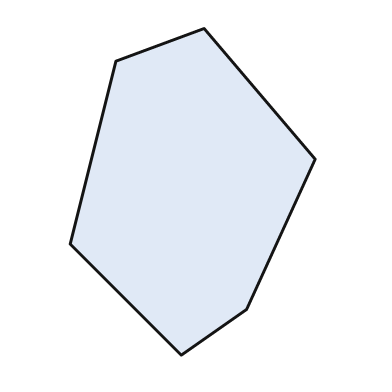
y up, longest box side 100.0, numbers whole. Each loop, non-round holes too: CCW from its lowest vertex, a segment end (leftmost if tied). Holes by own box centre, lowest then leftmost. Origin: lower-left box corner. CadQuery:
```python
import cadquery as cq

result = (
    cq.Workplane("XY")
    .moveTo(34.0, 0.0)
    .lineTo(54.0, 14.0)
    .lineTo(75.0, 60.0)
    .lineTo(41.0, 100.0)
    .lineTo(14.0, 90.0)
    .lineTo(0.0, 34.0)
    .close()
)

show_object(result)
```